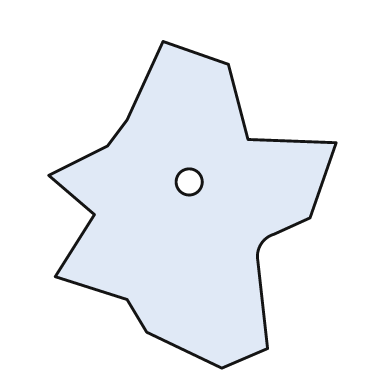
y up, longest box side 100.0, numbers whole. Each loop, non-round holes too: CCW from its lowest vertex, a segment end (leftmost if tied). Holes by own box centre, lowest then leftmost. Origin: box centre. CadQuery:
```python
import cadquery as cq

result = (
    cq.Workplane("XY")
    .moveTo(9.0, -50.0)
    .lineTo(23.0, -44.0)
    .lineTo(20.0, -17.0)
    .threePointArc((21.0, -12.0), (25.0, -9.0))
    .lineTo(36.0, -4.0)
    .lineTo(44.0, 19.0)
    .lineTo(17.0, 20.0)
    .lineTo(11.0, 43.0)
    .lineTo(-9.0, 50.0)
    .lineTo(-20.0, 26.0)
    .lineTo(-26.0, 18.0)
    .lineTo(-44.0, 9.0)
    .lineTo(-30.0, -3.0)
    .lineTo(-42.0, -22.0)
    .lineTo(-20.0, -29.0)
    .lineTo(-14.0, -39.0)
    .close()
    .moveTo(-1.0, 7.0)
    .circle(4.0)
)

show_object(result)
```